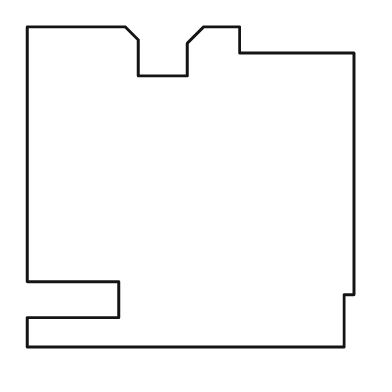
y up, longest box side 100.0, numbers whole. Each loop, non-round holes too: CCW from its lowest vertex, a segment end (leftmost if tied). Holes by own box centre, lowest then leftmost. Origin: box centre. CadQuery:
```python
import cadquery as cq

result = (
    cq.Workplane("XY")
    .moveTo(-50.0, -49.0)
    .lineTo(47.0, -49.0)
    .lineTo(47.0, -33.0)
    .lineTo(50.0, -33.0)
    .lineTo(50.0, 41.0)
    .lineTo(15.0, 41.0)
    .lineTo(15.0, 49.0)
    .lineTo(4.0, 49.0)
    .lineTo(-1.0, 44.0)
    .lineTo(-1.0, 34.0)
    .lineTo(-16.0, 34.0)
    .lineTo(-16.0, 45.0)
    .lineTo(-20.0, 49.0)
    .lineTo(-50.0, 49.0)
    .lineTo(-50.0, -29.0)
    .lineTo(-22.0, -29.0)
    .lineTo(-22.0, -40.0)
    .lineTo(-50.0, -40.0)
    .close()
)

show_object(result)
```